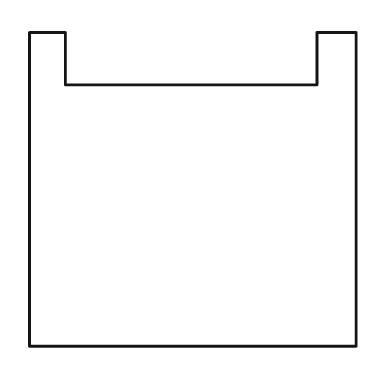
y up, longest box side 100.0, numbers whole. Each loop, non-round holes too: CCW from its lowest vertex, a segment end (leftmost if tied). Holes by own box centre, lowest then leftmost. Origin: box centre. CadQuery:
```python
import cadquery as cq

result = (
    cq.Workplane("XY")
    .moveTo(-50.0, -48.0)
    .lineTo(50.0, -48.0)
    .lineTo(50.0, 48.0)
    .lineTo(38.0, 48.0)
    .lineTo(38.0, 32.0)
    .lineTo(-39.0, 32.0)
    .lineTo(-39.0, 48.0)
    .lineTo(-50.0, 48.0)
    .close()
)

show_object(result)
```